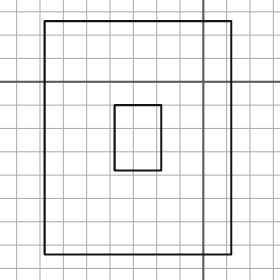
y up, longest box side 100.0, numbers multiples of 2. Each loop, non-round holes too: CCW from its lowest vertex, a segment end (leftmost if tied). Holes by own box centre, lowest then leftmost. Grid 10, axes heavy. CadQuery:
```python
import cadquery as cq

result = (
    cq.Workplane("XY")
    .moveTo(-68.0, -74.0)
    .lineTo(12.0, -74.0)
    .lineTo(12.0, 26.0)
    .lineTo(-68.0, 26.0)
    .close()
    .moveTo(-38.0, -38.0)
    .lineTo(-18.0, -38.0)
    .lineTo(-18.0, -10.0)
    .lineTo(-38.0, -10.0)
    .close()
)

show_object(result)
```